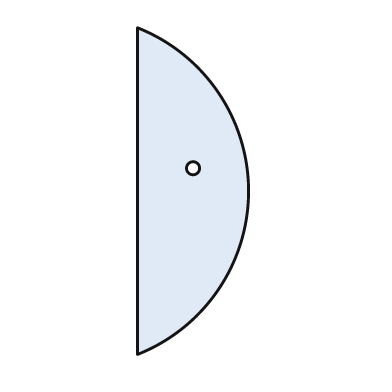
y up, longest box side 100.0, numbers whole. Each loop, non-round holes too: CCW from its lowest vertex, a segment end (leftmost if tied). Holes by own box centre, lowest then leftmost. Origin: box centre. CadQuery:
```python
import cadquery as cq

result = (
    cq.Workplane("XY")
    .moveTo(-17.0, -50.0)
    .threePointArc((17.0, 0.0), (-17.0, 50.0))
    .close()
    .moveTo(0.0, 7.0)
    .circle(2.0)
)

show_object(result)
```